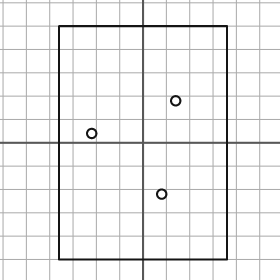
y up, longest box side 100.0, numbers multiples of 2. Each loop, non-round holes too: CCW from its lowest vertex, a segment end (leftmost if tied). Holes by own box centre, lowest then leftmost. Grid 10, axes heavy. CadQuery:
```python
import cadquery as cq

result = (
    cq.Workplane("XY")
    .moveTo(-36.0, -50.0)
    .lineTo(36.0, -50.0)
    .lineTo(36.0, 50.0)
    .lineTo(-36.0, 50.0)
    .close()
    .moveTo(8.0, -22.0)
    .circle(2.0)
    .moveTo(-22.0, 4.0)
    .circle(2.0)
    .moveTo(14.0, 18.0)
    .circle(2.0)
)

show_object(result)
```